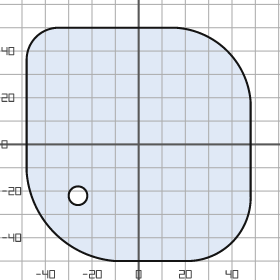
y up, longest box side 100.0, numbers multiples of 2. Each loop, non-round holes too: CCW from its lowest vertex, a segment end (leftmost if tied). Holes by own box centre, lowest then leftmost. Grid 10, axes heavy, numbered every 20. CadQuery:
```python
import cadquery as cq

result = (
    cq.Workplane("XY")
    .moveTo(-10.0, -50.0)
    .lineTo(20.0, -50.0)
    .threePointArc((40.0, -42.0), (48.0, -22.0))
    .lineTo(48.0, 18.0)
    .threePointArc((38.0, 40.0), (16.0, 50.0))
    .lineTo(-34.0, 50.0)
    .threePointArc((-44.0, 46.0), (-48.0, 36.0))
    .lineTo(-48.0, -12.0)
    .threePointArc((-36.0, -38.0), (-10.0, -50.0))
    .close()
    .moveTo(-26.0, -22.0)
    .circle(4.0)
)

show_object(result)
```